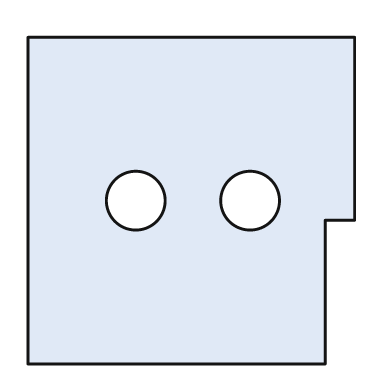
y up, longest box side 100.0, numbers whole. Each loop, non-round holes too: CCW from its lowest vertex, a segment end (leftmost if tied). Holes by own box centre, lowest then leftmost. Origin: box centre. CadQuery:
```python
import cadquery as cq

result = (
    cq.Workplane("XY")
    .moveTo(-50.0, -50.0)
    .lineTo(41.0, -50.0)
    .lineTo(41.0, -6.0)
    .lineTo(50.0, -6.0)
    .lineTo(50.0, 50.0)
    .lineTo(-50.0, 50.0)
    .close()
    .moveTo(-17.0, 0.0)
    .circle(9.0)
    .moveTo(18.0, 0.0)
    .circle(9.0)
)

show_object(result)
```